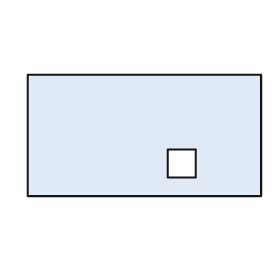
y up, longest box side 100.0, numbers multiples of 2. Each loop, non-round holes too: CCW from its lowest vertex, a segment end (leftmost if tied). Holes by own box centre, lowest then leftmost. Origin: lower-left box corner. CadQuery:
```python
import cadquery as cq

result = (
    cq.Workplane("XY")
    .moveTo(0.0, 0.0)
    .lineTo(100.0, 0.0)
    .lineTo(100.0, 52.0)
    .lineTo(0.0, 52.0)
    .close()
    .moveTo(60.0, 8.0)
    .lineTo(72.0, 8.0)
    .lineTo(72.0, 20.0)
    .lineTo(60.0, 20.0)
    .close()
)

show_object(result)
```